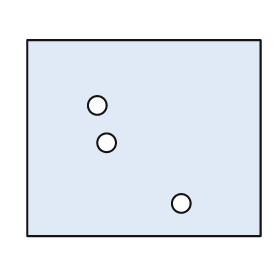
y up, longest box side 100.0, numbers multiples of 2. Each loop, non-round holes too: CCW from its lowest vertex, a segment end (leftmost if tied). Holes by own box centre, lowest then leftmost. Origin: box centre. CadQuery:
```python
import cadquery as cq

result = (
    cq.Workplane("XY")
    .moveTo(-50.0, -42.0)
    .lineTo(50.0, -42.0)
    .lineTo(50.0, 42.0)
    .lineTo(-50.0, 42.0)
    .close()
    .moveTo(16.0, -28.0)
    .circle(4.0)
    .moveTo(-16.0, -2.0)
    .circle(4.0)
    .moveTo(-20.0, 14.0)
    .circle(4.0)
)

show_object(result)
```